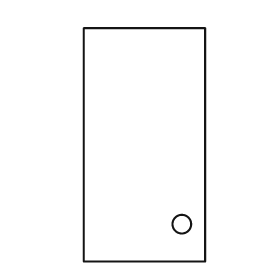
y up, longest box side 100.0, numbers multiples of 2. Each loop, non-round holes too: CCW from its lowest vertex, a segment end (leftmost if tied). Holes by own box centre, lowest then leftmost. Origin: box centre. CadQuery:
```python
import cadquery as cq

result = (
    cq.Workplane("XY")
    .moveTo(-26.0, -50.0)
    .lineTo(26.0, -50.0)
    .lineTo(26.0, 50.0)
    .lineTo(-26.0, 50.0)
    .close()
    .moveTo(16.0, -34.0)
    .circle(4.0)
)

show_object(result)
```